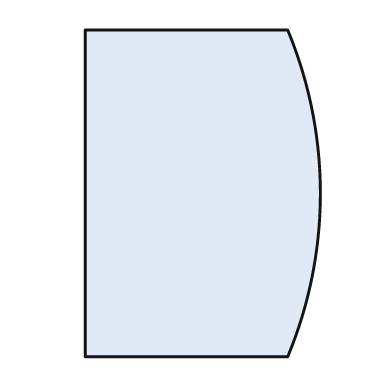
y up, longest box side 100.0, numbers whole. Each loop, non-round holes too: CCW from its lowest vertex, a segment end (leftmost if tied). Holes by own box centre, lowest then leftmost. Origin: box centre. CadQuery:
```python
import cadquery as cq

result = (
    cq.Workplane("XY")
    .moveTo(-36.0, -50.0)
    .lineTo(26.0, -50.0)
    .threePointArc((36.0, 0.0), (26.0, 50.0))
    .lineTo(-36.0, 50.0)
    .close()
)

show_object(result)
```